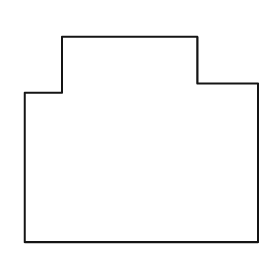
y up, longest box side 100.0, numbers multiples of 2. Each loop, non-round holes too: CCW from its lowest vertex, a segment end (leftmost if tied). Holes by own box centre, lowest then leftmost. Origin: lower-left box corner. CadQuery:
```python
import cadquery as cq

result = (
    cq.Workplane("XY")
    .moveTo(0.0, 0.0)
    .lineTo(100.0, 0.0)
    .lineTo(100.0, 68.0)
    .lineTo(74.0, 68.0)
    .lineTo(74.0, 88.0)
    .lineTo(16.0, 88.0)
    .lineTo(16.0, 64.0)
    .lineTo(0.0, 64.0)
    .close()
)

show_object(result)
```